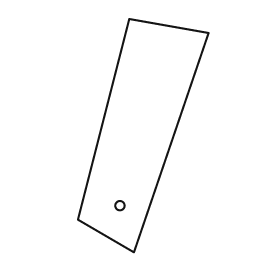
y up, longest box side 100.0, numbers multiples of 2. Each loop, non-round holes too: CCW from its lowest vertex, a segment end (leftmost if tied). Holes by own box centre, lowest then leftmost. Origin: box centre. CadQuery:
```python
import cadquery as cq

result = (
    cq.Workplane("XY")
    .moveTo(-4.0, -50.0)
    .lineTo(28.0, 44.0)
    .lineTo(-6.0, 50.0)
    .lineTo(-28.0, -36.0)
    .close()
    .moveTo(-10.0, -30.0)
    .circle(2.0)
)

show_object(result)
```